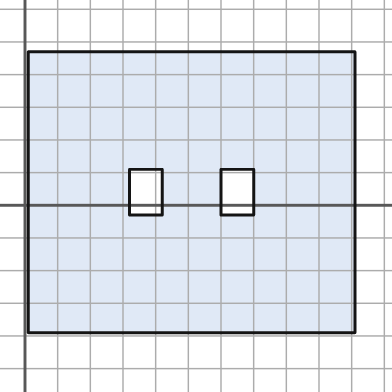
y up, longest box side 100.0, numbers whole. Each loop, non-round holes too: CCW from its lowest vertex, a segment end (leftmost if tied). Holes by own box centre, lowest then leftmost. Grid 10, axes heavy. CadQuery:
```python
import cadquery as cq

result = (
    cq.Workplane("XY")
    .moveTo(1.0, -39.0)
    .lineTo(101.0, -39.0)
    .lineTo(101.0, 47.0)
    .lineTo(1.0, 47.0)
    .close()
    .moveTo(32.0, -3.0)
    .lineTo(42.0, -3.0)
    .lineTo(42.0, 11.0)
    .lineTo(32.0, 11.0)
    .close()
    .moveTo(60.0, -3.0)
    .lineTo(70.0, -3.0)
    .lineTo(70.0, 11.0)
    .lineTo(60.0, 11.0)
    .close()
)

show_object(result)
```